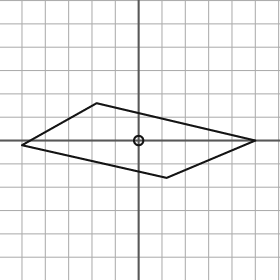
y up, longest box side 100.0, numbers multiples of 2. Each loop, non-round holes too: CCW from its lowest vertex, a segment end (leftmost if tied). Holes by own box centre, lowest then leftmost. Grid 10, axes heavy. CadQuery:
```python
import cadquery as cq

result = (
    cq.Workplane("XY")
    .moveTo(12.0, -16.0)
    .lineTo(50.0, 0.0)
    .lineTo(-18.0, 16.0)
    .lineTo(-50.0, -2.0)
    .close()
    .moveTo(0.0, 0.0)
    .circle(2.0)
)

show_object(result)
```